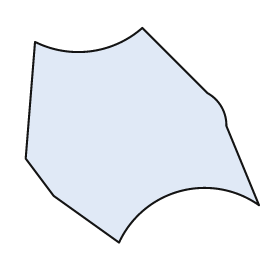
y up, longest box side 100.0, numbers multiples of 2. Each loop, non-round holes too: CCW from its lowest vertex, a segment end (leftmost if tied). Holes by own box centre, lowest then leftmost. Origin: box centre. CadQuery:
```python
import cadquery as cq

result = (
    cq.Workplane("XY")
    .moveTo(-10.0, -46.0)
    .threePointArc((16.0, -24.0), (50.0, -30.0))
    .lineTo(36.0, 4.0)
    .threePointArc((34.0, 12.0), (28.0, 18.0))
    .lineTo(0.0, 46.0)
    .threePointArc((-22.0, 36.0), (-46.0, 40.0))
    .lineTo(-50.0, -10.0)
    .lineTo(-38.0, -26.0)
    .close()
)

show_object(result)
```